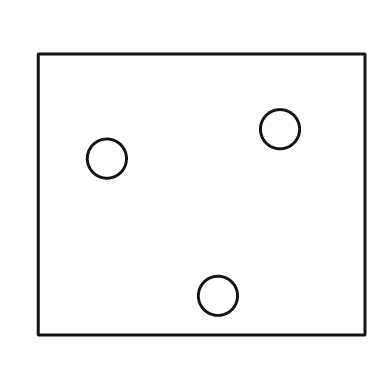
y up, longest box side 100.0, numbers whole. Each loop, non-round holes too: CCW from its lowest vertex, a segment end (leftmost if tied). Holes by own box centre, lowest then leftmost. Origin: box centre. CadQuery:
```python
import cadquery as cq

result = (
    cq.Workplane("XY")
    .moveTo(-50.0, -43.0)
    .lineTo(50.0, -43.0)
    .lineTo(50.0, 43.0)
    .lineTo(-50.0, 43.0)
    .close()
    .moveTo(5.0, -31.0)
    .circle(6.0)
    .moveTo(-29.0, 11.0)
    .circle(6.0)
    .moveTo(24.0, 20.0)
    .circle(6.0)
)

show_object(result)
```